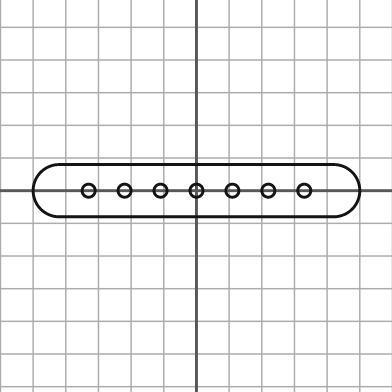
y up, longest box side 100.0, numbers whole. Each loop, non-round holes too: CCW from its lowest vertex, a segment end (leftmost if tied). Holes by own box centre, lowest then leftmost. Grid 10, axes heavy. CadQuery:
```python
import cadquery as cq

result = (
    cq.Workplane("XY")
    .moveTo(-42.0, -8.0)
    .lineTo(42.0, -8.0)
    .threePointArc((50.0, 0.0), (42.0, 8.0))
    .lineTo(-42.0, 8.0)
    .threePointArc((-50.0, 0.0), (-42.0, -8.0))
    .close()
    .moveTo(-33.0, 0.0)
    .circle(2.0)
    .moveTo(-22.0, 0.0)
    .circle(2.0)
    .moveTo(-11.0, 0.0)
    .circle(2.0)
    .moveTo(0.0, 0.0)
    .circle(2.0)
    .moveTo(11.0, 0.0)
    .circle(2.0)
    .moveTo(22.0, 0.0)
    .circle(2.0)
    .moveTo(33.0, 0.0)
    .circle(2.0)
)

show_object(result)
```